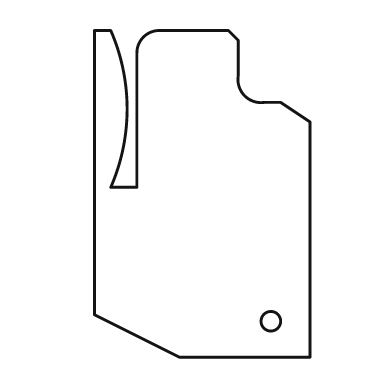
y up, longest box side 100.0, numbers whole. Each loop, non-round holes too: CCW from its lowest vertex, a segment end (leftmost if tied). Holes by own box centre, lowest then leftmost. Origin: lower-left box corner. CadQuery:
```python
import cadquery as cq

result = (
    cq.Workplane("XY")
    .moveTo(26.0, 0.0)
    .lineTo(66.0, 0.0)
    .lineTo(66.0, 72.0)
    .lineTo(57.0, 78.0)
    .lineTo(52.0, 78.0)
    .threePointArc((46.0, 80.0), (44.0, 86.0))
    .lineTo(44.0, 97.0)
    .lineTo(41.0, 100.0)
    .lineTo(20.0, 100.0)
    .threePointArc((15.0, 98.0), (13.0, 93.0))
    .lineTo(13.0, 52.0)
    .lineTo(5.0, 52.0)
    .threePointArc((10.0, 76.0), (5.0, 100.0))
    .lineTo(0.0, 100.0)
    .lineTo(0.0, 13.0)
    .close()
    .moveTo(54.0, 11.0)
    .circle(3.0)
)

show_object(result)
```